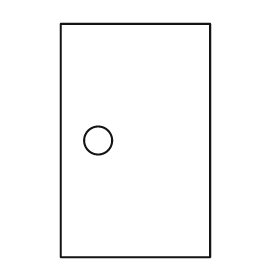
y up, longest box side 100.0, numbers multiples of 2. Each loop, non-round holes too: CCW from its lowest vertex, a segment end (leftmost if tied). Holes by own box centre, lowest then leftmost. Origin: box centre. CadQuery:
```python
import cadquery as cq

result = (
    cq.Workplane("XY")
    .moveTo(-32.0, -50.0)
    .lineTo(32.0, -50.0)
    .lineTo(32.0, 50.0)
    .lineTo(-32.0, 50.0)
    .close()
    .moveTo(-16.0, 0.0)
    .circle(6.0)
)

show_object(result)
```